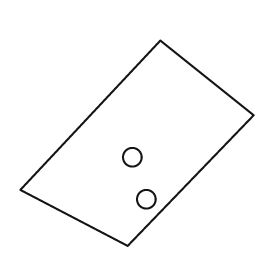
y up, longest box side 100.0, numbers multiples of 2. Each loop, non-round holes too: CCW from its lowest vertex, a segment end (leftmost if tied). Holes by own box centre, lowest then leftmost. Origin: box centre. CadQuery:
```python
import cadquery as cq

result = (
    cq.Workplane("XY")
    .moveTo(-4.0, -44.0)
    .lineTo(50.0, 12.0)
    .lineTo(10.0, 44.0)
    .lineTo(-50.0, -20.0)
    .close()
    .moveTo(4.0, -24.0)
    .circle(4.0)
    .moveTo(-2.0, -6.0)
    .circle(4.0)
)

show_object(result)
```